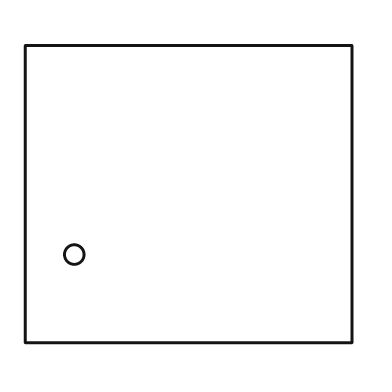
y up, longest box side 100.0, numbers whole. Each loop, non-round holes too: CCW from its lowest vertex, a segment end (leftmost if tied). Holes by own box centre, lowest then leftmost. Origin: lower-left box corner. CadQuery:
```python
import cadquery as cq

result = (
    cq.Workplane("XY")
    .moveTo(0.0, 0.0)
    .lineTo(100.0, 0.0)
    .lineTo(100.0, 91.0)
    .lineTo(0.0, 91.0)
    .close()
    .moveTo(15.0, 27.0)
    .circle(3.0)
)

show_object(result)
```